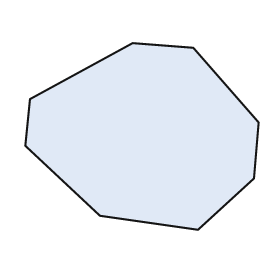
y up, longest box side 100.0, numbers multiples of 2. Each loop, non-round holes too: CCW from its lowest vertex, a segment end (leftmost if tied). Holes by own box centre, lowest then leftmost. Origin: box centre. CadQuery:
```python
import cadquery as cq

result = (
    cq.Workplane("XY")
    .moveTo(24.0, -40.0)
    .lineTo(48.0, -18.0)
    .lineTo(50.0, 6.0)
    .lineTo(22.0, 38.0)
    .lineTo(-4.0, 40.0)
    .lineTo(-48.0, 16.0)
    .lineTo(-50.0, -4.0)
    .lineTo(-18.0, -34.0)
    .close()
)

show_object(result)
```